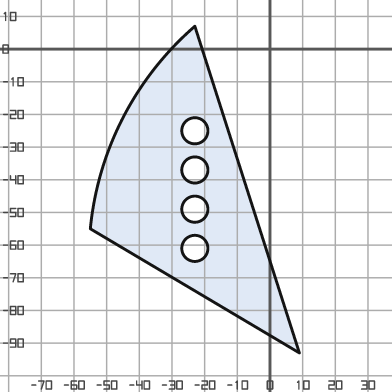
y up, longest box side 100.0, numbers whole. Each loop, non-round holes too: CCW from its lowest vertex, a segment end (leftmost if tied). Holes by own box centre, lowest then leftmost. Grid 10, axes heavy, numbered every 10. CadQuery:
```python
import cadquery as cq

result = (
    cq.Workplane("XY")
    .moveTo(9.0, -93.0)
    .lineTo(-23.0, 7.0)
    .threePointArc((-45.0, -21.0), (-55.0, -55.0))
    .close()
    .moveTo(-23.0, -61.0)
    .circle(4.0)
    .moveTo(-23.0, -49.0)
    .circle(4.0)
    .moveTo(-23.0, -37.0)
    .circle(4.0)
    .moveTo(-23.0, -25.0)
    .circle(4.0)
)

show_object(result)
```